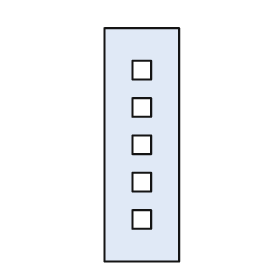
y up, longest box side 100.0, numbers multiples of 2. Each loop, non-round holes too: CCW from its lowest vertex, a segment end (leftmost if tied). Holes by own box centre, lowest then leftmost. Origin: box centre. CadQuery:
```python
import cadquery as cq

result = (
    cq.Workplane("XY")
    .moveTo(-16.0, -50.0)
    .lineTo(16.0, -50.0)
    .lineTo(16.0, 50.0)
    .lineTo(-16.0, 50.0)
    .close()
    .moveTo(-4.0, -36.0)
    .lineTo(4.0, -36.0)
    .lineTo(4.0, -28.0)
    .lineTo(-4.0, -28.0)
    .close()
    .moveTo(-4.0, -20.0)
    .lineTo(4.0, -20.0)
    .lineTo(4.0, -12.0)
    .lineTo(-4.0, -12.0)
    .close()
    .moveTo(-4.0, -4.0)
    .lineTo(4.0, -4.0)
    .lineTo(4.0, 4.0)
    .lineTo(-4.0, 4.0)
    .close()
    .moveTo(-4.0, 12.0)
    .lineTo(4.0, 12.0)
    .lineTo(4.0, 20.0)
    .lineTo(-4.0, 20.0)
    .close()
    .moveTo(-4.0, 28.0)
    .lineTo(4.0, 28.0)
    .lineTo(4.0, 36.0)
    .lineTo(-4.0, 36.0)
    .close()
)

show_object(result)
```